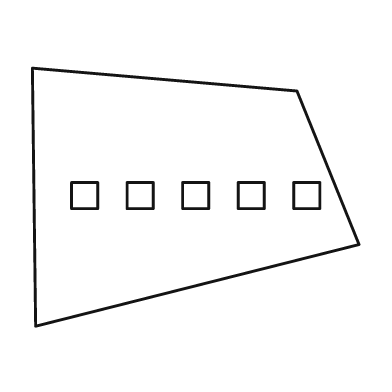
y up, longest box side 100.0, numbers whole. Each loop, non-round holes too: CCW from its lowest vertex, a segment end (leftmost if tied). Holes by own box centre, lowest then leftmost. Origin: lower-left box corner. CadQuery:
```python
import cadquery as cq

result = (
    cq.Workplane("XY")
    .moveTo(1.0, 0.0)
    .lineTo(100.0, 25.0)
    .lineTo(81.0, 72.0)
    .lineTo(0.0, 79.0)
    .close()
    .moveTo(12.0, 36.0)
    .lineTo(20.0, 36.0)
    .lineTo(20.0, 44.0)
    .lineTo(12.0, 44.0)
    .close()
    .moveTo(29.0, 36.0)
    .lineTo(37.0, 36.0)
    .lineTo(37.0, 44.0)
    .lineTo(29.0, 44.0)
    .close()
    .moveTo(46.0, 36.0)
    .lineTo(54.0, 36.0)
    .lineTo(54.0, 44.0)
    .lineTo(46.0, 44.0)
    .close()
    .moveTo(63.0, 36.0)
    .lineTo(71.0, 36.0)
    .lineTo(71.0, 44.0)
    .lineTo(63.0, 44.0)
    .close()
    .moveTo(80.0, 36.0)
    .lineTo(88.0, 36.0)
    .lineTo(88.0, 44.0)
    .lineTo(80.0, 44.0)
    .close()
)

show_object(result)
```